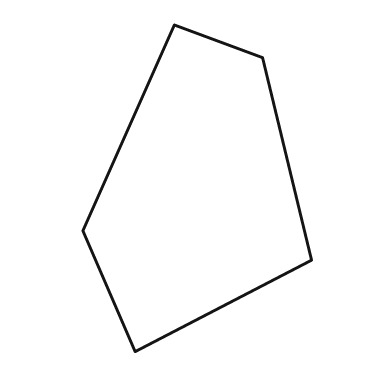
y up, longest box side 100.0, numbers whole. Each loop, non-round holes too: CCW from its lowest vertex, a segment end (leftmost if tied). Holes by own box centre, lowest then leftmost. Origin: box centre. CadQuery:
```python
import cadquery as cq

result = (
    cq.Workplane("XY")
    .moveTo(-19.0, -50.0)
    .lineTo(35.0, -22.0)
    .lineTo(20.0, 40.0)
    .lineTo(-7.0, 50.0)
    .lineTo(-35.0, -13.0)
    .close()
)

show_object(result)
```